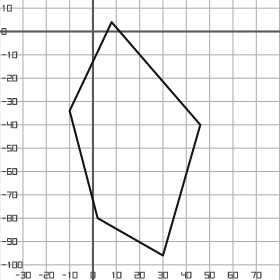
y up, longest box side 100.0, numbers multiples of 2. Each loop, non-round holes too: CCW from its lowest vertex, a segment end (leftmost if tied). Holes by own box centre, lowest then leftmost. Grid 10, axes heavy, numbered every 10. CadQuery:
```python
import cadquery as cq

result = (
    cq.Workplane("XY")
    .moveTo(30.0, -96.0)
    .lineTo(46.0, -40.0)
    .lineTo(8.0, 4.0)
    .lineTo(-10.0, -34.0)
    .lineTo(2.0, -80.0)
    .close()
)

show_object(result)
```